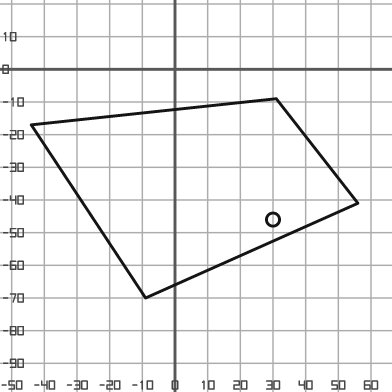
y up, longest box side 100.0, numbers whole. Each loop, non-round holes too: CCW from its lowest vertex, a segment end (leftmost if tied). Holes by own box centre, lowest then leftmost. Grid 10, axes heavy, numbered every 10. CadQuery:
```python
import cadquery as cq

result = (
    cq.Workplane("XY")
    .moveTo(-9.0, -70.0)
    .lineTo(56.0, -41.0)
    .lineTo(31.0, -9.0)
    .lineTo(-44.0, -17.0)
    .close()
    .moveTo(30.0, -46.0)
    .circle(2.0)
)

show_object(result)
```